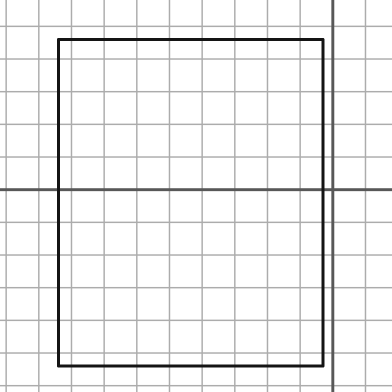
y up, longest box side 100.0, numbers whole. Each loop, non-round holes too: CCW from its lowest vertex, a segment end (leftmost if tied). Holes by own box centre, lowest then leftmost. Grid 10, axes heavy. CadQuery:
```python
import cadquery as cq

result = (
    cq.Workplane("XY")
    .moveTo(-84.0, -54.0)
    .lineTo(-3.0, -54.0)
    .lineTo(-3.0, 46.0)
    .lineTo(-84.0, 46.0)
    .close()
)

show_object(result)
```